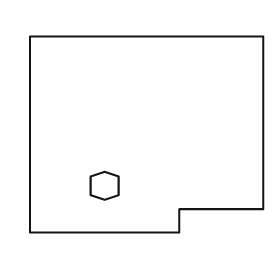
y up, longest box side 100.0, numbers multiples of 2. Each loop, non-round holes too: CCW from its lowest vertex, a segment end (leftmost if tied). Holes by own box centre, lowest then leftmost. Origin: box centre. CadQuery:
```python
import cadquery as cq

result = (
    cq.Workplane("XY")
    .moveTo(-50.0, -42.0)
    .lineTo(14.0, -42.0)
    .lineTo(14.0, -32.0)
    .lineTo(50.0, -32.0)
    .lineTo(50.0, 42.0)
    .lineTo(-50.0, 42.0)
    .close()
    .moveTo(-18.0, -28.0)
    .lineTo(-12.0, -26.0)
    .lineTo(-12.0, -18.0)
    .lineTo(-18.0, -16.0)
    .lineTo(-24.0, -18.0)
    .lineTo(-24.0, -26.0)
    .close()
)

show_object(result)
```